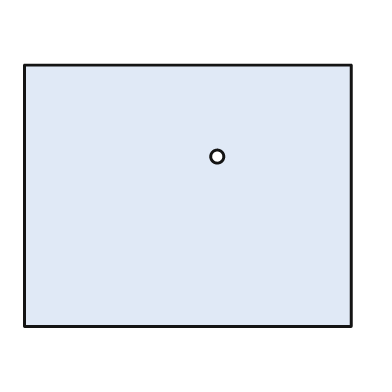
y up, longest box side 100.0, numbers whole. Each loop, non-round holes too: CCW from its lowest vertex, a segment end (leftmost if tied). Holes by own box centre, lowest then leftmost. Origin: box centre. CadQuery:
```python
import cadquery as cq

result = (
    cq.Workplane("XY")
    .moveTo(-50.0, -40.0)
    .lineTo(50.0, -40.0)
    .lineTo(50.0, 40.0)
    .lineTo(-50.0, 40.0)
    .close()
    .moveTo(9.0, 12.0)
    .circle(2.0)
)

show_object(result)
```